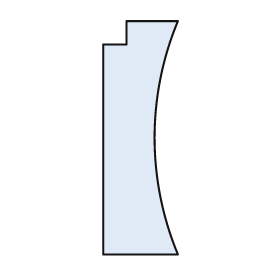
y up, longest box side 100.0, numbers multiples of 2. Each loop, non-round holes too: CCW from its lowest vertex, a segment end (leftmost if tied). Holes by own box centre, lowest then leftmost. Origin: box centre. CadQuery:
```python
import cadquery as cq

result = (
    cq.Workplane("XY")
    .moveTo(-16.0, -50.0)
    .lineTo(16.0, -50.0)
    .threePointArc((6.0, 0.0), (16.0, 50.0))
    .lineTo(-6.0, 50.0)
    .lineTo(-6.0, 40.0)
    .lineTo(-16.0, 40.0)
    .close()
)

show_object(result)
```